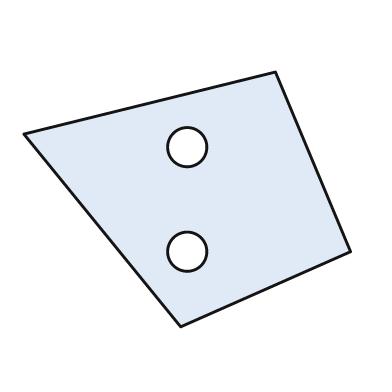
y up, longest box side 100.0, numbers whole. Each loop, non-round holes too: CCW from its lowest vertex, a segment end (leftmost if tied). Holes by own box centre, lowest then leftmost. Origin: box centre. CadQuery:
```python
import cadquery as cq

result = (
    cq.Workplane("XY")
    .moveTo(-2.0, -39.0)
    .lineTo(50.0, -16.0)
    .lineTo(27.0, 39.0)
    .lineTo(-50.0, 20.0)
    .close()
    .moveTo(0.0, -16.0)
    .circle(6.0)
    .moveTo(0.0, 16.0)
    .circle(6.0)
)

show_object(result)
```